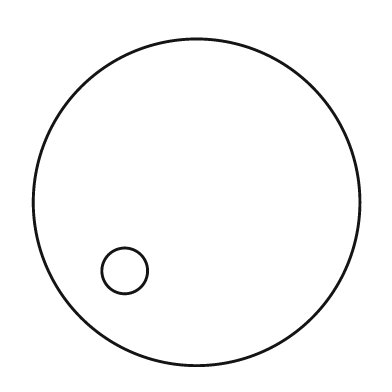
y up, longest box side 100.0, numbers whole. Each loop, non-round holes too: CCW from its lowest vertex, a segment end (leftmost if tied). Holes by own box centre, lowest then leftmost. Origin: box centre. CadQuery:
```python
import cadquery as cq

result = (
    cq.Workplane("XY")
    .moveTo(0.0, 0.0)
    .circle(50.0)
    .moveTo(-22.0, -21.0)
    .circle(7.0)
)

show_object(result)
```